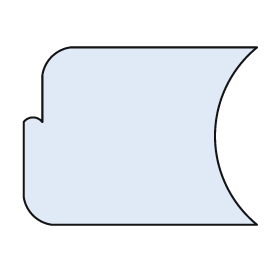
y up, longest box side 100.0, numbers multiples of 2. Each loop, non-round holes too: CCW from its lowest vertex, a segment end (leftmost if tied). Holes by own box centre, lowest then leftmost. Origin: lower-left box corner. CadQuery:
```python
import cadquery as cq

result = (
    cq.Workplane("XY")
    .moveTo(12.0, 0.0)
    .lineTo(100.0, 0.0)
    .threePointArc((82.0, 38.0), (100.0, 76.0))
    .lineTo(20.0, 76.0)
    .threePointArc((12.0, 72.0), (8.0, 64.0))
    .lineTo(8.0, 44.0)
    .threePointArc((4.0, 46.0), (0.0, 44.0))
    .lineTo(0.0, 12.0)
    .threePointArc((4.0, 4.0), (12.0, 0.0))
    .close()
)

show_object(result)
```